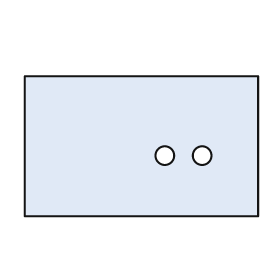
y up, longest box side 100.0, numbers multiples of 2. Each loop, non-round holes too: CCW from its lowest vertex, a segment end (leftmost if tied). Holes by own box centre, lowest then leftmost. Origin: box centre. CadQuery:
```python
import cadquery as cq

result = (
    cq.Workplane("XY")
    .moveTo(-50.0, -30.0)
    .lineTo(50.0, -30.0)
    .lineTo(50.0, 30.0)
    .lineTo(-50.0, 30.0)
    .close()
    .moveTo(10.0, -4.0)
    .circle(4.0)
    .moveTo(26.0, -4.0)
    .circle(4.0)
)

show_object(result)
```